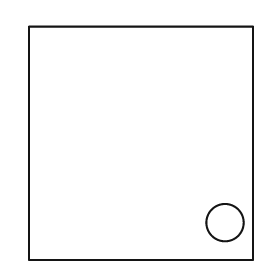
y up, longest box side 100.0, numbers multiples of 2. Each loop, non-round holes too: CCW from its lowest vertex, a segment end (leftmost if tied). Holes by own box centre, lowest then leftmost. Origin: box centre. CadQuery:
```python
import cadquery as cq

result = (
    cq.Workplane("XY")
    .moveTo(-48.0, -50.0)
    .lineTo(48.0, -50.0)
    .lineTo(48.0, 50.0)
    .lineTo(-48.0, 50.0)
    .close()
    .moveTo(36.0, -34.0)
    .circle(8.0)
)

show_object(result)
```